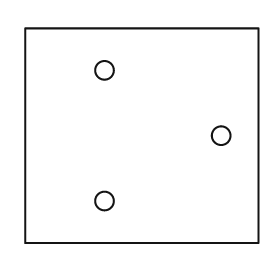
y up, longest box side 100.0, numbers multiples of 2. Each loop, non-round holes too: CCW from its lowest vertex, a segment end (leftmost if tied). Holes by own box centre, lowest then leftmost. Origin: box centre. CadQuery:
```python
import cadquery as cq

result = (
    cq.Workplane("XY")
    .moveTo(-50.0, -46.0)
    .lineTo(50.0, -46.0)
    .lineTo(50.0, 46.0)
    .lineTo(-50.0, 46.0)
    .close()
    .moveTo(-16.0, -28.0)
    .circle(4.0)
    .moveTo(34.0, 0.0)
    .circle(4.0)
    .moveTo(-16.0, 28.0)
    .circle(4.0)
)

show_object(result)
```